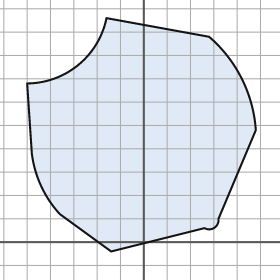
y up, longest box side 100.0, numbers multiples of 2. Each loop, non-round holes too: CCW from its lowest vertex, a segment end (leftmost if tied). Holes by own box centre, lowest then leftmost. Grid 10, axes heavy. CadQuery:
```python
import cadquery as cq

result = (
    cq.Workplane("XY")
    .moveTo(-14.0, -4.0)
    .lineTo(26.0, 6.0)
    .threePointArc((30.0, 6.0), (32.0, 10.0))
    .lineTo(48.0, 48.0)
    .threePointArc((42.0, 70.0), (28.0, 88.0))
    .lineTo(-16.0, 96.0)
    .threePointArc((-28.0, 76.0), (-50.0, 68.0))
    .lineTo(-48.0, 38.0)
    .threePointArc((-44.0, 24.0), (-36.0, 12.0))
    .close()
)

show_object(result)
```